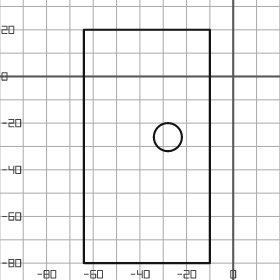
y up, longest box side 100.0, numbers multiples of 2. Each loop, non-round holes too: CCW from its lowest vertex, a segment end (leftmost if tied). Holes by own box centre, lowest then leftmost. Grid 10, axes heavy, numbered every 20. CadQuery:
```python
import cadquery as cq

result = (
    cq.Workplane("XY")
    .moveTo(-64.0, -80.0)
    .lineTo(-10.0, -80.0)
    .lineTo(-10.0, 20.0)
    .lineTo(-64.0, 20.0)
    .close()
    .moveTo(-28.0, -26.0)
    .circle(6.0)
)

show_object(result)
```